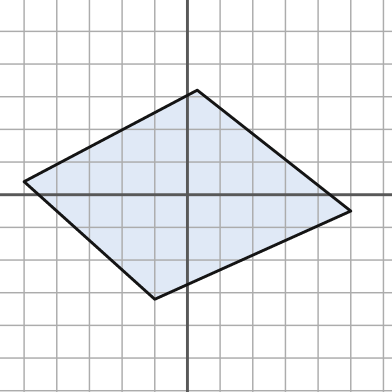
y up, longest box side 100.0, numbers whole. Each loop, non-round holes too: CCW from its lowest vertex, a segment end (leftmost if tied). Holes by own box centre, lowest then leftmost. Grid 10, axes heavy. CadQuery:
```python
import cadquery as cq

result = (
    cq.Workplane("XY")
    .moveTo(-10.0, -32.0)
    .lineTo(50.0, -5.0)
    .lineTo(3.0, 32.0)
    .lineTo(-50.0, 4.0)
    .close()
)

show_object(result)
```